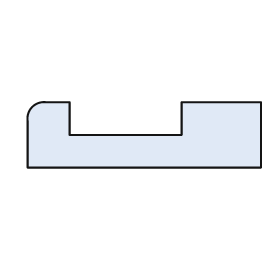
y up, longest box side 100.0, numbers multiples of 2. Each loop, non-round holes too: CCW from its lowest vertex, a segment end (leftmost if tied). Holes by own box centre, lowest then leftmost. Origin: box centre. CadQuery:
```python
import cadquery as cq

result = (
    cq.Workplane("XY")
    .moveTo(-50.0, -14.0)
    .lineTo(50.0, -14.0)
    .lineTo(50.0, 14.0)
    .lineTo(16.0, 14.0)
    .lineTo(16.0, 0.0)
    .lineTo(-32.0, 0.0)
    .lineTo(-32.0, 14.0)
    .lineTo(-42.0, 14.0)
    .threePointArc((-48.0, 12.0), (-50.0, 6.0))
    .close()
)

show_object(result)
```